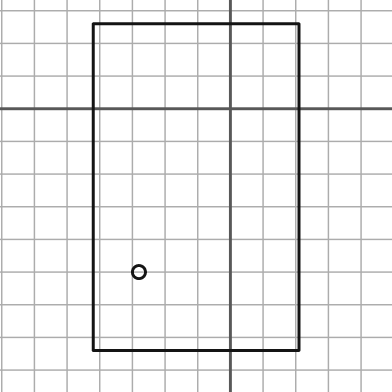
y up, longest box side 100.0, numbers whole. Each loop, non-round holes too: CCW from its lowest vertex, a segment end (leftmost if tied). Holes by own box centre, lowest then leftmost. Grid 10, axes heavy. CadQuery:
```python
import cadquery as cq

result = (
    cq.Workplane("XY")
    .moveTo(-42.0, -74.0)
    .lineTo(21.0, -74.0)
    .lineTo(21.0, 26.0)
    .lineTo(-42.0, 26.0)
    .close()
    .moveTo(-28.0, -50.0)
    .circle(2.0)
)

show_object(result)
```